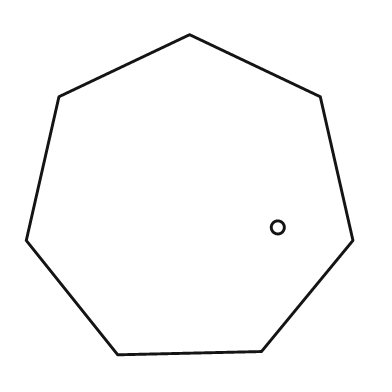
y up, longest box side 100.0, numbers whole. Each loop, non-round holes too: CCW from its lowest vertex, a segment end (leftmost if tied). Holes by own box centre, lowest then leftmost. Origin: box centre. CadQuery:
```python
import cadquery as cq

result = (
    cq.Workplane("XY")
    .moveTo(-22.0, -49.0)
    .lineTo(22.0, -48.0)
    .lineTo(50.0, -14.0)
    .lineTo(40.0, 30.0)
    .lineTo(0.0, 49.0)
    .lineTo(-40.0, 30.0)
    .lineTo(-50.0, -14.0)
    .close()
    .moveTo(27.0, -10.0)
    .circle(2.0)
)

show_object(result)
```